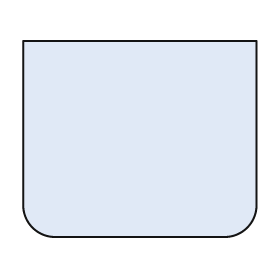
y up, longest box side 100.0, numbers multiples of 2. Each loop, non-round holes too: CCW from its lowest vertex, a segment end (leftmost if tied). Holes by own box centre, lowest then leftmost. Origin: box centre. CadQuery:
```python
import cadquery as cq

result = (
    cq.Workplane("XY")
    .moveTo(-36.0, -42.0)
    .lineTo(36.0, -42.0)
    .threePointArc((46.0, -38.0), (50.0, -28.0))
    .lineTo(50.0, 42.0)
    .lineTo(-50.0, 42.0)
    .lineTo(-50.0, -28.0)
    .threePointArc((-46.0, -38.0), (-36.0, -42.0))
    .close()
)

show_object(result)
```